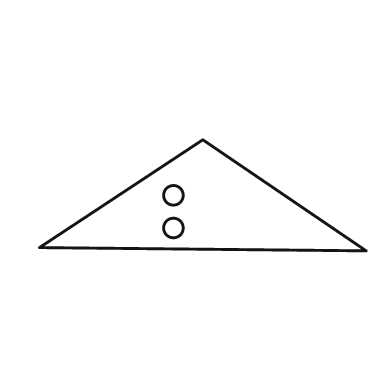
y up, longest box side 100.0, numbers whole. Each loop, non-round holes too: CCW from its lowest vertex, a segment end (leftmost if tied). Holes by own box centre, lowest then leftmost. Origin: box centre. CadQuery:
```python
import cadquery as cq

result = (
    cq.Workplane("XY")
    .moveTo(50.0, -17.0)
    .lineTo(0.0, 17.0)
    .lineTo(-50.0, -16.0)
    .close()
    .moveTo(-9.0, -10.0)
    .circle(3.0)
    .moveTo(-9.0, 0.0)
    .circle(3.0)
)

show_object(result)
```